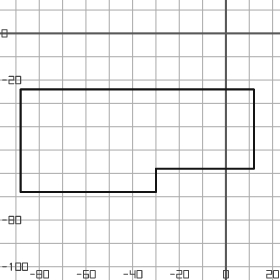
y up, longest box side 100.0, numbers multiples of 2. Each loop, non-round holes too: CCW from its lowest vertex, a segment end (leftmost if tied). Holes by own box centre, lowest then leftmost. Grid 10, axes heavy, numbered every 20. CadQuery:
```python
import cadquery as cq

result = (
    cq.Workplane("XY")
    .moveTo(-88.0, -68.0)
    .lineTo(-30.0, -68.0)
    .lineTo(-30.0, -58.0)
    .lineTo(12.0, -58.0)
    .lineTo(12.0, -24.0)
    .lineTo(-88.0, -24.0)
    .close()
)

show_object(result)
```